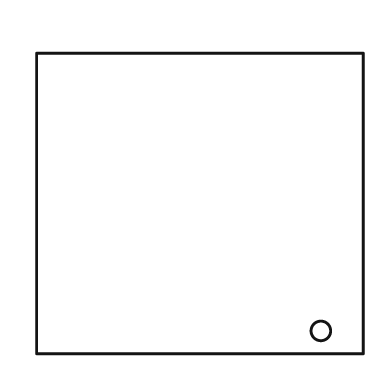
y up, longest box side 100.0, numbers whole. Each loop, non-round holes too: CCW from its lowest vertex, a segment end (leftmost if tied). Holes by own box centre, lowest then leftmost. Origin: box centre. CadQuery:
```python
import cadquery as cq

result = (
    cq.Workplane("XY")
    .moveTo(-50.0, -46.0)
    .lineTo(50.0, -46.0)
    .lineTo(50.0, 46.0)
    .lineTo(-50.0, 46.0)
    .close()
    .moveTo(37.0, -39.0)
    .circle(3.0)
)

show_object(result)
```